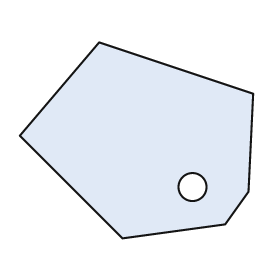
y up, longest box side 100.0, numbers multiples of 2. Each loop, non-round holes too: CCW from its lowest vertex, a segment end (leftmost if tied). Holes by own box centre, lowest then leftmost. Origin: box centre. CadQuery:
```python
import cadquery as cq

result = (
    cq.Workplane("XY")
    .moveTo(-6.0, -42.0)
    .lineTo(38.0, -36.0)
    .lineTo(48.0, -22.0)
    .lineTo(50.0, 20.0)
    .lineTo(-16.0, 42.0)
    .lineTo(-50.0, 2.0)
    .close()
    .moveTo(24.0, -20.0)
    .circle(6.0)
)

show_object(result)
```